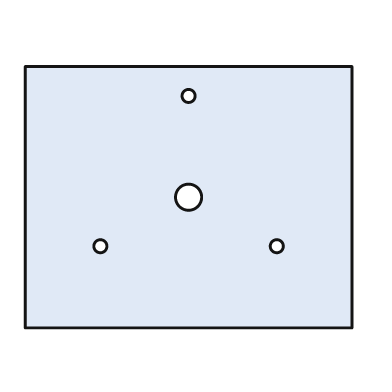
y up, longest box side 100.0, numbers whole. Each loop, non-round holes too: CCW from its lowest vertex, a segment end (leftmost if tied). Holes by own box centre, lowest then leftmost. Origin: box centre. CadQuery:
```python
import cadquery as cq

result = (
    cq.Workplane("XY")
    .moveTo(-50.0, -40.0)
    .lineTo(50.0, -40.0)
    .lineTo(50.0, 40.0)
    .lineTo(-50.0, 40.0)
    .close()
    .moveTo(-27.0, -15.0)
    .circle(2.0)
    .moveTo(27.0, -15.0)
    .circle(2.0)
    .moveTo(0.0, 0.0)
    .circle(4.0)
    .moveTo(0.0, 31.0)
    .circle(2.0)
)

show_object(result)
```